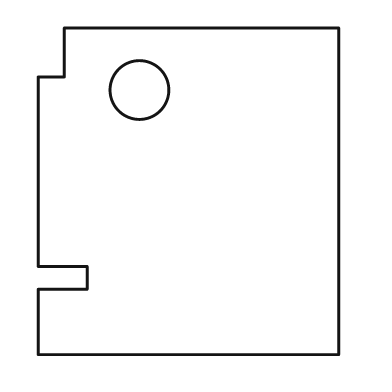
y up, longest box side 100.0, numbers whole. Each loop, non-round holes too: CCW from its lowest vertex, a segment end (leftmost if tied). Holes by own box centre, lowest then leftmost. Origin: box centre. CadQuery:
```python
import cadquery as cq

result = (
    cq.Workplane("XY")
    .moveTo(-46.0, -50.0)
    .lineTo(46.0, -50.0)
    .lineTo(46.0, 50.0)
    .lineTo(-38.0, 50.0)
    .lineTo(-38.0, 35.0)
    .lineTo(-46.0, 35.0)
    .lineTo(-46.0, -23.0)
    .lineTo(-31.0, -23.0)
    .lineTo(-31.0, -30.0)
    .lineTo(-46.0, -30.0)
    .close()
    .moveTo(-15.0, 31.0)
    .circle(9.0)
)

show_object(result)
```